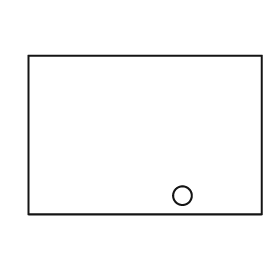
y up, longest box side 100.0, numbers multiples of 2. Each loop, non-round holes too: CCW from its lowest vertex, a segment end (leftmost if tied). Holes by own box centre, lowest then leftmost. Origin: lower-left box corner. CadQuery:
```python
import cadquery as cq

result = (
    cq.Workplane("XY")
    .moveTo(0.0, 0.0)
    .lineTo(100.0, 0.0)
    .lineTo(100.0, 68.0)
    .lineTo(0.0, 68.0)
    .close()
    .moveTo(66.0, 8.0)
    .circle(4.0)
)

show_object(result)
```